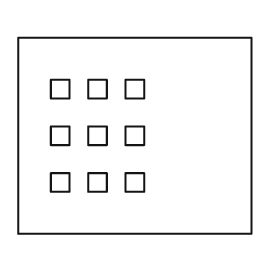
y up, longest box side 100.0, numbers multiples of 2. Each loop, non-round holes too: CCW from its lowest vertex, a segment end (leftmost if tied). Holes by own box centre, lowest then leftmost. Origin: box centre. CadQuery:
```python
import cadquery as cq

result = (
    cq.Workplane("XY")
    .moveTo(-50.0, -42.0)
    .lineTo(50.0, -42.0)
    .lineTo(50.0, 42.0)
    .lineTo(-50.0, 42.0)
    .close()
    .moveTo(-36.0, -24.0)
    .lineTo(-28.0, -24.0)
    .lineTo(-28.0, -16.0)
    .lineTo(-36.0, -16.0)
    .close()
    .moveTo(-20.0, -24.0)
    .lineTo(-12.0, -24.0)
    .lineTo(-12.0, -16.0)
    .lineTo(-20.0, -16.0)
    .close()
    .moveTo(-4.0, -24.0)
    .lineTo(4.0, -24.0)
    .lineTo(4.0, -16.0)
    .lineTo(-4.0, -16.0)
    .close()
    .moveTo(-36.0, -4.0)
    .lineTo(-28.0, -4.0)
    .lineTo(-28.0, 4.0)
    .lineTo(-36.0, 4.0)
    .close()
    .moveTo(-20.0, -4.0)
    .lineTo(-12.0, -4.0)
    .lineTo(-12.0, 4.0)
    .lineTo(-20.0, 4.0)
    .close()
    .moveTo(-4.0, -4.0)
    .lineTo(4.0, -4.0)
    .lineTo(4.0, 4.0)
    .lineTo(-4.0, 4.0)
    .close()
    .moveTo(-36.0, 16.0)
    .lineTo(-28.0, 16.0)
    .lineTo(-28.0, 24.0)
    .lineTo(-36.0, 24.0)
    .close()
    .moveTo(-20.0, 16.0)
    .lineTo(-12.0, 16.0)
    .lineTo(-12.0, 24.0)
    .lineTo(-20.0, 24.0)
    .close()
    .moveTo(-4.0, 16.0)
    .lineTo(4.0, 16.0)
    .lineTo(4.0, 24.0)
    .lineTo(-4.0, 24.0)
    .close()
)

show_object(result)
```